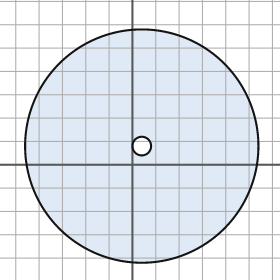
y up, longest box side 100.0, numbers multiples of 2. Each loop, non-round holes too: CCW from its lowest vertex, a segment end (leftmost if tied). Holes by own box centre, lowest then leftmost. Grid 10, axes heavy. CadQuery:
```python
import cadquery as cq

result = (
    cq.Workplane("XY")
    .moveTo(4.0, 8.0)
    .circle(50.0)
    .moveTo(4.0, 8.0)
    .circle(4.0)
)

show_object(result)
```